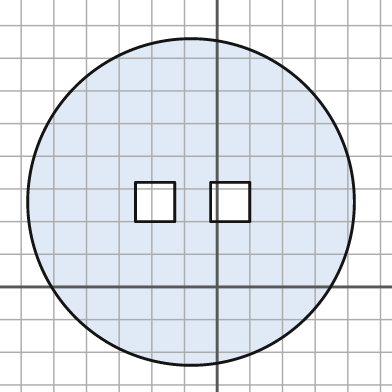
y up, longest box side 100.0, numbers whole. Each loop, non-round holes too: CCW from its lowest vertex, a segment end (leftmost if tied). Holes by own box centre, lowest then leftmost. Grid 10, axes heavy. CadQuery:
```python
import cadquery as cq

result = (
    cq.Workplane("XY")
    .moveTo(-8.0, 26.0)
    .circle(50.0)
    .moveTo(-25.0, 20.0)
    .lineTo(-13.0, 20.0)
    .lineTo(-13.0, 32.0)
    .lineTo(-25.0, 32.0)
    .close()
    .moveTo(-2.0, 20.0)
    .lineTo(10.0, 20.0)
    .lineTo(10.0, 32.0)
    .lineTo(-2.0, 32.0)
    .close()
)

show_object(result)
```